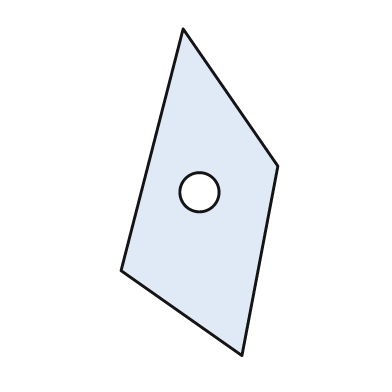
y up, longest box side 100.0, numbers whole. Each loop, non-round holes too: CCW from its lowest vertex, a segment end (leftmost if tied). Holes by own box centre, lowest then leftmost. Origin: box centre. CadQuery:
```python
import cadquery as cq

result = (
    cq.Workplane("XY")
    .moveTo(13.0, -50.0)
    .lineTo(24.0, 8.0)
    .lineTo(-5.0, 50.0)
    .lineTo(-24.0, -24.0)
    .close()
    .moveTo(0.0, 0.0)
    .circle(6.0)
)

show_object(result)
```